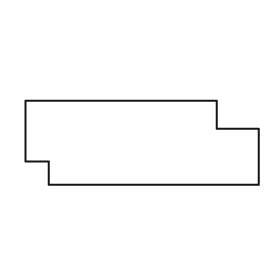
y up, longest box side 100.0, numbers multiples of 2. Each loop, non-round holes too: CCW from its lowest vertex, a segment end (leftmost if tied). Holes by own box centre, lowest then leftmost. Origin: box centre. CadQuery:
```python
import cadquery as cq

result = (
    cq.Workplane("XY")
    .moveTo(-40.0, -18.0)
    .lineTo(50.0, -18.0)
    .lineTo(50.0, 6.0)
    .lineTo(32.0, 6.0)
    .lineTo(32.0, 18.0)
    .lineTo(-50.0, 18.0)
    .lineTo(-50.0, -8.0)
    .lineTo(-40.0, -8.0)
    .close()
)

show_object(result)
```